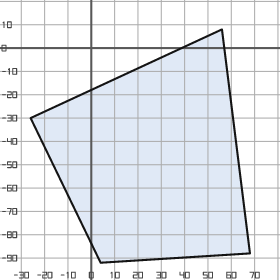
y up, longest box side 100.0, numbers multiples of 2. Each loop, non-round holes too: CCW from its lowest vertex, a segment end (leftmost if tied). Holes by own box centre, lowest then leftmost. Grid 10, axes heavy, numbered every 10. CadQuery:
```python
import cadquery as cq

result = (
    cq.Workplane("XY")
    .moveTo(4.0, -92.0)
    .lineTo(68.0, -88.0)
    .lineTo(56.0, 8.0)
    .lineTo(-26.0, -30.0)
    .close()
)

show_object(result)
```